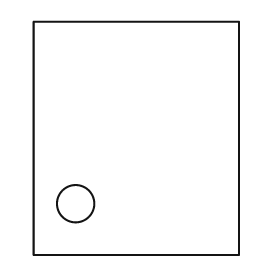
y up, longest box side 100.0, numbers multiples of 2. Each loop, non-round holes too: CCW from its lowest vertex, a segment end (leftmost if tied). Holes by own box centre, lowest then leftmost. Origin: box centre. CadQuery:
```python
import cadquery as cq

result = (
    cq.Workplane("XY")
    .moveTo(-44.0, -50.0)
    .lineTo(44.0, -50.0)
    .lineTo(44.0, 50.0)
    .lineTo(-44.0, 50.0)
    .close()
    .moveTo(-26.0, -28.0)
    .circle(8.0)
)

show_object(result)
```